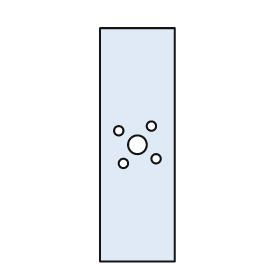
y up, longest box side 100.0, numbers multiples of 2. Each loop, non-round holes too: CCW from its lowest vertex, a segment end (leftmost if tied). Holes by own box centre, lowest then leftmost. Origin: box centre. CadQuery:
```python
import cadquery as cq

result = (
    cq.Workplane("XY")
    .moveTo(-16.0, -50.0)
    .lineTo(16.0, -50.0)
    .lineTo(16.0, 50.0)
    .lineTo(-16.0, 50.0)
    .close()
    .moveTo(-6.0, -8.0)
    .circle(2.0)
    .moveTo(8.0, -6.0)
    .circle(2.0)
    .moveTo(0.0, 0.0)
    .circle(4.0)
    .moveTo(-8.0, 6.0)
    .circle(2.0)
    .moveTo(6.0, 8.0)
    .circle(2.0)
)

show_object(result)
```